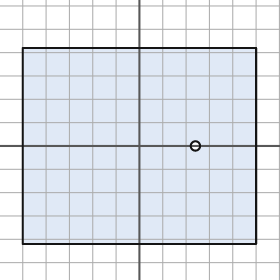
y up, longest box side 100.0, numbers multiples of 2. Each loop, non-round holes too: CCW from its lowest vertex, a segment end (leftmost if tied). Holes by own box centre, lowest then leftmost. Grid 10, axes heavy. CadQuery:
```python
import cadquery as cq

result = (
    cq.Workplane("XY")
    .moveTo(-50.0, -42.0)
    .lineTo(50.0, -42.0)
    .lineTo(50.0, 42.0)
    .lineTo(-50.0, 42.0)
    .close()
    .moveTo(24.0, 0.0)
    .circle(2.0)
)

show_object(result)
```